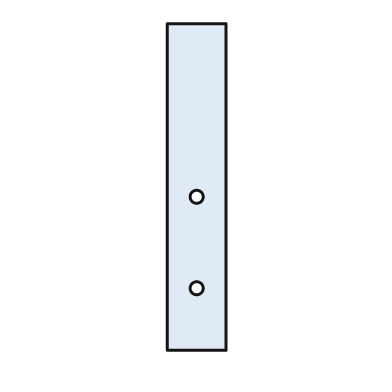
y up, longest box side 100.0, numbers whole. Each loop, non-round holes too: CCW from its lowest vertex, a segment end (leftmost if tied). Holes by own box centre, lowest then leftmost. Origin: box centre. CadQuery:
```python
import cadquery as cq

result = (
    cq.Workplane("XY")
    .moveTo(-9.0, -50.0)
    .lineTo(9.0, -50.0)
    .lineTo(9.0, 50.0)
    .lineTo(-9.0, 50.0)
    .close()
    .moveTo(0.0, -31.0)
    .circle(2.0)
    .moveTo(0.0, -3.0)
    .circle(2.0)
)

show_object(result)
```